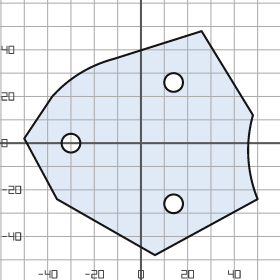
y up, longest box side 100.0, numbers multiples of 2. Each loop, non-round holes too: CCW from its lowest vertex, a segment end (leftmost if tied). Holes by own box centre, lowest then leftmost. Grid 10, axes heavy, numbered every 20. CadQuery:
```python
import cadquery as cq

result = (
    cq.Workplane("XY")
    .moveTo(6.0, -48.0)
    .lineTo(50.0, -24.0)
    .threePointArc((46.0, -6.0), (48.0, 12.0))
    .lineTo(26.0, 48.0)
    .lineTo(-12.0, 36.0)
    .threePointArc((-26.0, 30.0), (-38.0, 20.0))
    .lineTo(-50.0, 2.0)
    .lineTo(-36.0, -24.0)
    .close()
    .moveTo(14.0, -26.0)
    .circle(4.0)
    .moveTo(-30.0, 0.0)
    .circle(4.0)
    .moveTo(14.0, 26.0)
    .circle(4.0)
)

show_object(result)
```